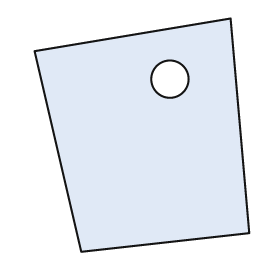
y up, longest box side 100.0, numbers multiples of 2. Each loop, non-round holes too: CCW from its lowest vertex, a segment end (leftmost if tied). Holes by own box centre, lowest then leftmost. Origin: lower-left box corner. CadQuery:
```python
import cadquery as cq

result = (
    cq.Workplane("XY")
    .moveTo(20.0, 0.0)
    .lineTo(92.0, 8.0)
    .lineTo(84.0, 100.0)
    .lineTo(0.0, 86.0)
    .close()
    .moveTo(58.0, 74.0)
    .circle(8.0)
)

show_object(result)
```